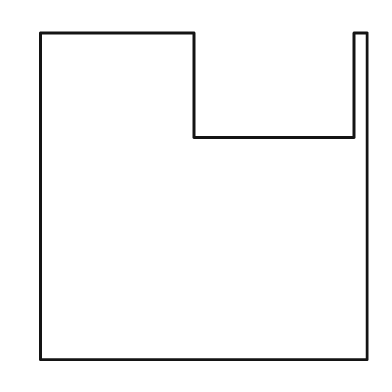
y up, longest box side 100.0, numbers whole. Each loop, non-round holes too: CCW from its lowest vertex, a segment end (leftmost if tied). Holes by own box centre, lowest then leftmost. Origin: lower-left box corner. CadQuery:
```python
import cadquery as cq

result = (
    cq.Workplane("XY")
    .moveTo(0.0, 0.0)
    .lineTo(100.0, 0.0)
    .lineTo(100.0, 100.0)
    .lineTo(96.0, 100.0)
    .lineTo(96.0, 68.0)
    .lineTo(47.0, 68.0)
    .lineTo(47.0, 100.0)
    .lineTo(0.0, 100.0)
    .close()
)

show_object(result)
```